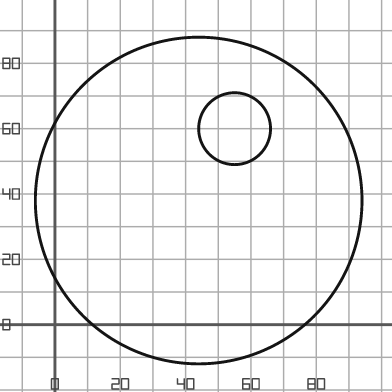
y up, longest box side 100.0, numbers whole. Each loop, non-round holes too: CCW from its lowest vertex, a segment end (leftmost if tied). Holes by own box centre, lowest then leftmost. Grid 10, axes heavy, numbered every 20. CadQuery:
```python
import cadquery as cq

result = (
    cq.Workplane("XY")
    .moveTo(44.0, 38.0)
    .circle(50.0)
    .moveTo(55.0, 60.0)
    .circle(11.0)
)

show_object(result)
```